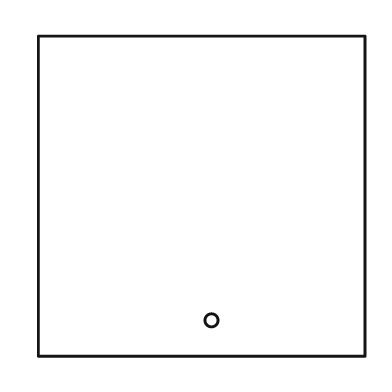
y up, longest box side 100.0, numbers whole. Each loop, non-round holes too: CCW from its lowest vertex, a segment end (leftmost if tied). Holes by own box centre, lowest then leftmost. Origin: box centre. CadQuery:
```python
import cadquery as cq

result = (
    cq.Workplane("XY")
    .moveTo(-50.0, -49.0)
    .lineTo(50.0, -49.0)
    .lineTo(50.0, 49.0)
    .lineTo(-50.0, 49.0)
    .close()
    .moveTo(3.0, -38.0)
    .circle(2.0)
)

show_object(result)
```